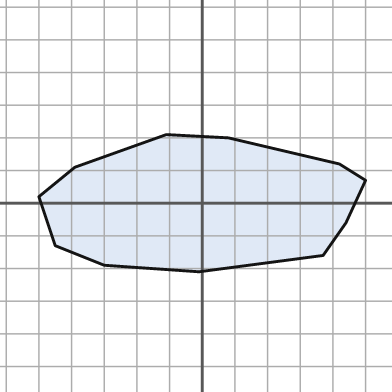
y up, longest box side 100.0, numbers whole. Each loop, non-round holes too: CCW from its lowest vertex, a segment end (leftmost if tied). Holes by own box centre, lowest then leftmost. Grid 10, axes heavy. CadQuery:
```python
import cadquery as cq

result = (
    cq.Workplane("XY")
    .moveTo(-1.0, -21.0)
    .lineTo(37.0, -16.0)
    .lineTo(44.0, -6.0)
    .lineTo(50.0, 7.0)
    .lineTo(42.0, 12.0)
    .lineTo(8.0, 20.0)
    .lineTo(-11.0, 21.0)
    .lineTo(-39.0, 11.0)
    .lineTo(-50.0, 2.0)
    .lineTo(-45.0, -13.0)
    .lineTo(-30.0, -19.0)
    .close()
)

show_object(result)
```